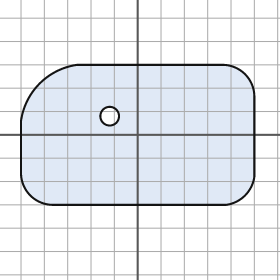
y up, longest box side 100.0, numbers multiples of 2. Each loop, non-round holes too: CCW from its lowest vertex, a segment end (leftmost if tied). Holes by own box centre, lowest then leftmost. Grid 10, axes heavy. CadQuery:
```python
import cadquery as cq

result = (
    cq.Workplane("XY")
    .moveTo(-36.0, -30.0)
    .lineTo(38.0, -30.0)
    .threePointArc((46.0, -26.0), (50.0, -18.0))
    .lineTo(50.0, 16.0)
    .threePointArc((46.0, 26.0), (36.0, 30.0))
    .lineTo(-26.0, 30.0)
    .threePointArc((-42.0, 22.0), (-50.0, 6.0))
    .lineTo(-50.0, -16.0)
    .threePointArc((-46.0, -26.0), (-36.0, -30.0))
    .close()
    .moveTo(-12.0, 8.0)
    .circle(4.0)
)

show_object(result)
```